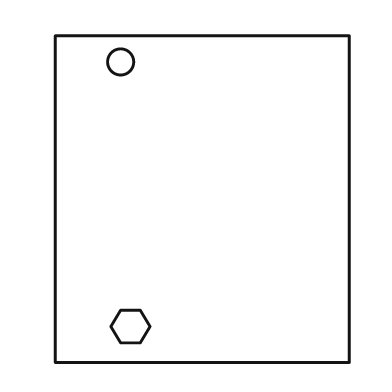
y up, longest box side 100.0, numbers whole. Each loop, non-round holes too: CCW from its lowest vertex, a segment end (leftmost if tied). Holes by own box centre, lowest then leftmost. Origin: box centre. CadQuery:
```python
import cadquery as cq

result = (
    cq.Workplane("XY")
    .moveTo(-45.0, -50.0)
    .lineTo(45.0, -50.0)
    .lineTo(45.0, 50.0)
    .lineTo(-45.0, 50.0)
    .close()
    .moveTo(-25.0, -44.0)
    .lineTo(-19.0, -44.0)
    .lineTo(-16.0, -39.0)
    .lineTo(-19.0, -34.0)
    .lineTo(-25.0, -34.0)
    .lineTo(-28.0, -39.0)
    .close()
    .moveTo(-25.0, 42.0)
    .circle(4.0)
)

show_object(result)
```